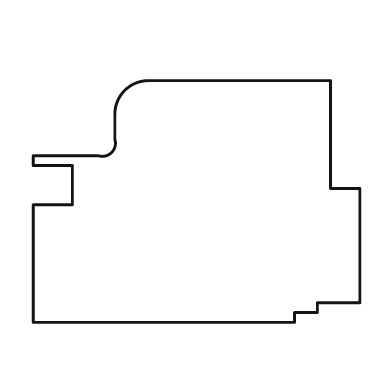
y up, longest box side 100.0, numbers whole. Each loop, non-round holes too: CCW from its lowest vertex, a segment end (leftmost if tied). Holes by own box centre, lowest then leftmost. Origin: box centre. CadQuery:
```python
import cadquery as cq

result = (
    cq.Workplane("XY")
    .moveTo(-50.0, -37.0)
    .lineTo(30.0, -37.0)
    .lineTo(30.0, -34.0)
    .lineTo(37.0, -34.0)
    .lineTo(37.0, -31.0)
    .lineTo(50.0, -31.0)
    .lineTo(50.0, 4.0)
    .lineTo(41.0, 4.0)
    .lineTo(41.0, 37.0)
    .lineTo(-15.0, 37.0)
    .threePointArc((-22.0, 34.0), (-25.0, 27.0))
    .lineTo(-25.0, 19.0)
    .threePointArc((-26.0, 15.0), (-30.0, 14.0))
    .lineTo(-50.0, 14.0)
    .lineTo(-50.0, 11.0)
    .lineTo(-38.0, 11.0)
    .lineTo(-38.0, -1.0)
    .lineTo(-50.0, -1.0)
    .close()
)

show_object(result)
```